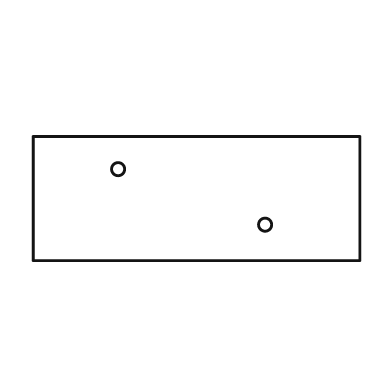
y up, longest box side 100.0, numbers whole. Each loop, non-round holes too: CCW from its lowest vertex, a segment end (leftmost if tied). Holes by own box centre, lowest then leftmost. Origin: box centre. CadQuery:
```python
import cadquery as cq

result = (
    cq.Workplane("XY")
    .moveTo(-50.0, -19.0)
    .lineTo(50.0, -19.0)
    .lineTo(50.0, 19.0)
    .lineTo(-50.0, 19.0)
    .close()
    .moveTo(21.0, -8.0)
    .circle(2.0)
    .moveTo(-24.0, 9.0)
    .circle(2.0)
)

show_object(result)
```